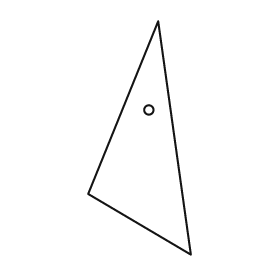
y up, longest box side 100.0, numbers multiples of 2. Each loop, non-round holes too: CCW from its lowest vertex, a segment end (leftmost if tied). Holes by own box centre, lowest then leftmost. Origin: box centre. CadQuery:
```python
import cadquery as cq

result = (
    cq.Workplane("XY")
    .moveTo(22.0, -50.0)
    .lineTo(8.0, 50.0)
    .lineTo(-22.0, -24.0)
    .close()
    .moveTo(4.0, 12.0)
    .circle(2.0)
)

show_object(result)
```